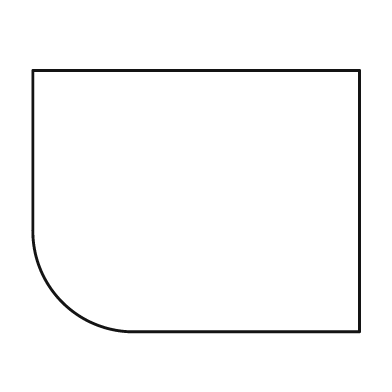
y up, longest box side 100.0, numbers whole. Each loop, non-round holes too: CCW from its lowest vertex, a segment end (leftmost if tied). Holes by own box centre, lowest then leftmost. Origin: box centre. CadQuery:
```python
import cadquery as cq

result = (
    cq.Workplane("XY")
    .moveTo(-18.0, -40.0)
    .lineTo(50.0, -40.0)
    .lineTo(50.0, 40.0)
    .lineTo(-50.0, 40.0)
    .lineTo(-50.0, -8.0)
    .threePointArc((-41.0, -31.0), (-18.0, -40.0))
    .close()
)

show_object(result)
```